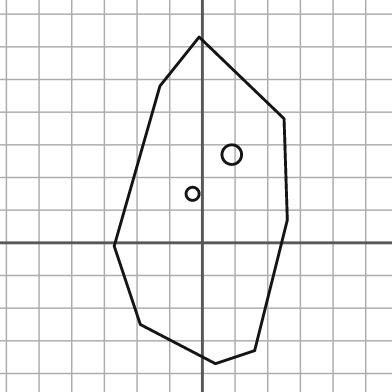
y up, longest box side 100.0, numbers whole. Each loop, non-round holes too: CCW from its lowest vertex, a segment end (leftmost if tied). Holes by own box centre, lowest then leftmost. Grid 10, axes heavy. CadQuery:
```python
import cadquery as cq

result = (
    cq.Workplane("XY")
    .moveTo(4.0, -37.0)
    .lineTo(16.0, -33.0)
    .lineTo(26.0, 7.0)
    .lineTo(25.0, 38.0)
    .lineTo(-1.0, 63.0)
    .lineTo(-13.0, 48.0)
    .lineTo(-27.0, -1.0)
    .lineTo(-19.0, -25.0)
    .close()
    .moveTo(-3.0, 15.0)
    .circle(2.0)
    .moveTo(9.0, 27.0)
    .circle(3.0)
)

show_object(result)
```